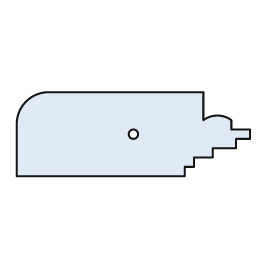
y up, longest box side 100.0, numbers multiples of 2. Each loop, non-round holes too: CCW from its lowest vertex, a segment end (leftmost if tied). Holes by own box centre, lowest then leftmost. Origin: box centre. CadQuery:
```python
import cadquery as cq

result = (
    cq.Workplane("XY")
    .moveTo(-50.0, -18.0)
    .lineTo(22.0, -18.0)
    .lineTo(22.0, -14.0)
    .lineTo(26.0, -14.0)
    .lineTo(26.0, -10.0)
    .lineTo(34.0, -10.0)
    .lineTo(34.0, -6.0)
    .lineTo(44.0, -6.0)
    .lineTo(44.0, -2.0)
    .lineTo(50.0, -2.0)
    .lineTo(50.0, 2.0)
    .lineTo(42.0, 2.0)
    .lineTo(42.0, 6.0)
    .threePointArc((36.0, 8.0), (30.0, 6.0))
    .lineTo(30.0, 18.0)
    .lineTo(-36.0, 18.0)
    .threePointArc((-46.0, 14.0), (-50.0, 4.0))
    .close()
    .moveTo(0.0, 0.0)
    .circle(2.0)
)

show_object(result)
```